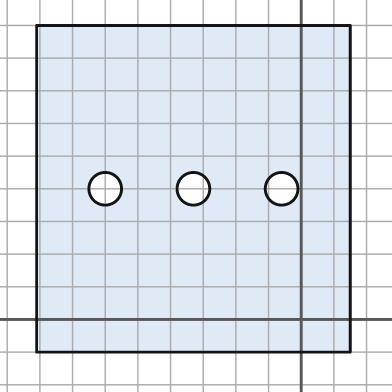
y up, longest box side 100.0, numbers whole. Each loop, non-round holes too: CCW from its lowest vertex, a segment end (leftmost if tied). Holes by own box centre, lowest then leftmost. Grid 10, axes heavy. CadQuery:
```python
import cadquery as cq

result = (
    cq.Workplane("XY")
    .moveTo(-81.0, -10.0)
    .lineTo(15.0, -10.0)
    .lineTo(15.0, 90.0)
    .lineTo(-81.0, 90.0)
    .close()
    .moveTo(-60.0, 40.0)
    .circle(5.0)
    .moveTo(-33.0, 40.0)
    .circle(5.0)
    .moveTo(-6.0, 40.0)
    .circle(5.0)
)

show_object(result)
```